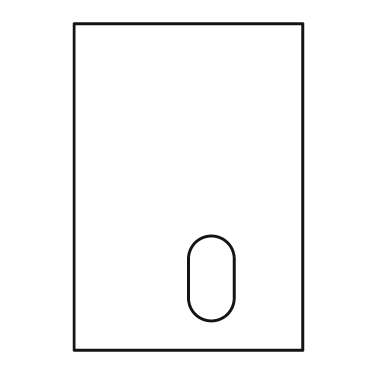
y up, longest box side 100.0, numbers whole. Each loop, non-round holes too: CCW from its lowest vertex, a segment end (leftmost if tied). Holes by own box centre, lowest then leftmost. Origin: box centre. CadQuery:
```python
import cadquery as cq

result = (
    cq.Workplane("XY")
    .moveTo(-35.0, -50.0)
    .lineTo(35.0, -50.0)
    .lineTo(35.0, 50.0)
    .lineTo(-35.0, 50.0)
    .close()
    .moveTo(0.0, -34.0)
    .threePointArc((7.0, -41.0), (14.0, -34.0))
    .lineTo(14.0, -22.0)
    .threePointArc((7.0, -15.0), (0.0, -22.0))
    .close()
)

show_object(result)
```